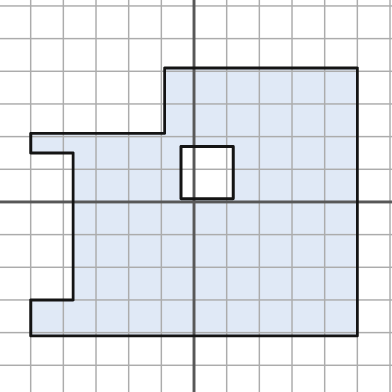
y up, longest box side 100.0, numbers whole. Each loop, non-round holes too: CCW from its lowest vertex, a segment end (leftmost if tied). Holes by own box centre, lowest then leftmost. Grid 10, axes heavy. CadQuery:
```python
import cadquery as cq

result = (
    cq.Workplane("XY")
    .moveTo(-50.0, -41.0)
    .lineTo(50.0, -41.0)
    .lineTo(50.0, 41.0)
    .lineTo(-9.0, 41.0)
    .lineTo(-9.0, 21.0)
    .lineTo(-50.0, 21.0)
    .lineTo(-50.0, 15.0)
    .lineTo(-37.0, 15.0)
    .lineTo(-37.0, -30.0)
    .lineTo(-50.0, -30.0)
    .close()
    .moveTo(-4.0, 1.0)
    .lineTo(12.0, 1.0)
    .lineTo(12.0, 17.0)
    .lineTo(-4.0, 17.0)
    .close()
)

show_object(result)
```